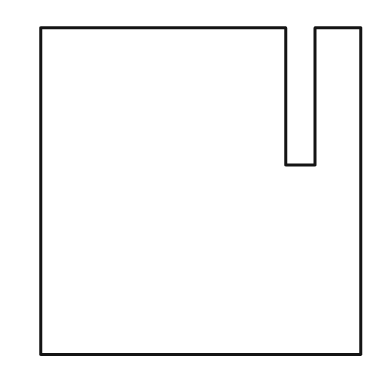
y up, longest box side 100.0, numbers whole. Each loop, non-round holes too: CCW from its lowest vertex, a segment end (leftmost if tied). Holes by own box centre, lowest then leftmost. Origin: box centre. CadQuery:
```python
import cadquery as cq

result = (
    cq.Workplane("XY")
    .moveTo(-49.0, -50.0)
    .lineTo(49.0, -50.0)
    .lineTo(49.0, 50.0)
    .lineTo(35.0, 50.0)
    .lineTo(35.0, 8.0)
    .lineTo(26.0, 8.0)
    .lineTo(26.0, 50.0)
    .lineTo(-49.0, 50.0)
    .close()
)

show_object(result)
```